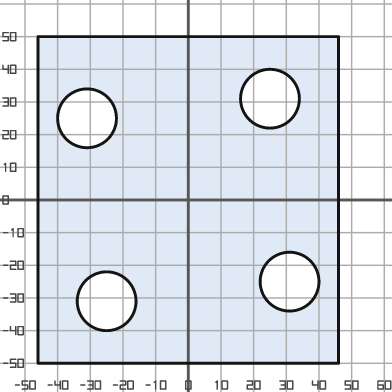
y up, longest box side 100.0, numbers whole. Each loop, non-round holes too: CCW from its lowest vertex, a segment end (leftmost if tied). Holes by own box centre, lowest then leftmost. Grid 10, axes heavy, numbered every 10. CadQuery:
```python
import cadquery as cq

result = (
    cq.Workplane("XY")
    .moveTo(-46.0, -50.0)
    .lineTo(46.0, -50.0)
    .lineTo(46.0, 50.0)
    .lineTo(-46.0, 50.0)
    .close()
    .moveTo(-25.0, -31.0)
    .circle(9.0)
    .moveTo(31.0, -25.0)
    .circle(9.0)
    .moveTo(-31.0, 25.0)
    .circle(9.0)
    .moveTo(25.0, 31.0)
    .circle(9.0)
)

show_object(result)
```